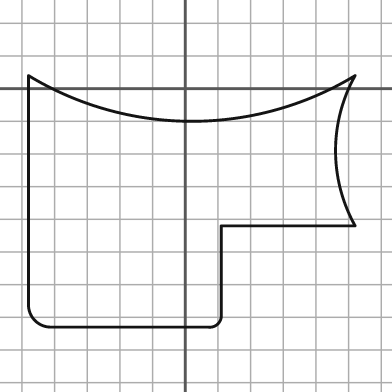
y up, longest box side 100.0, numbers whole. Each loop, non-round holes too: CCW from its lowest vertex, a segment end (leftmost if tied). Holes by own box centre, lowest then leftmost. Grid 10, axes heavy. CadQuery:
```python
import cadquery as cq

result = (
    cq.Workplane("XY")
    .moveTo(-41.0, -73.0)
    .lineTo(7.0, -73.0)
    .threePointArc((10.0, -72.0), (11.0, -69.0))
    .lineTo(11.0, -42.0)
    .lineTo(52.0, -42.0)
    .threePointArc((46.0, -19.0), (52.0, 4.0))
    .threePointArc((2.0, -10.0), (-48.0, 4.0))
    .lineTo(-48.0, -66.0)
    .threePointArc((-46.0, -71.0), (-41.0, -73.0))
    .close()
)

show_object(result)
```